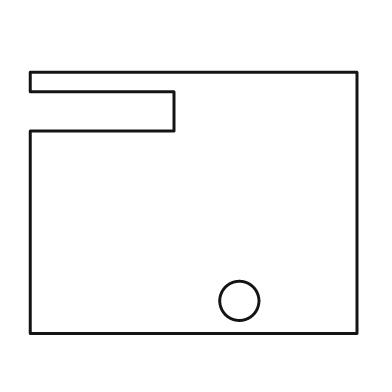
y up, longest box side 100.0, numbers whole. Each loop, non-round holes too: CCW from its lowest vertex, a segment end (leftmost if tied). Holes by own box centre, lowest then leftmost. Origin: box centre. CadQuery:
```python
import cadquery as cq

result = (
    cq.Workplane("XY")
    .moveTo(-50.0, -40.0)
    .lineTo(50.0, -40.0)
    .lineTo(50.0, 40.0)
    .lineTo(-50.0, 40.0)
    .lineTo(-50.0, 34.0)
    .lineTo(-6.0, 34.0)
    .lineTo(-6.0, 22.0)
    .lineTo(-50.0, 22.0)
    .close()
    .moveTo(14.0, -30.0)
    .circle(6.0)
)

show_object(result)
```